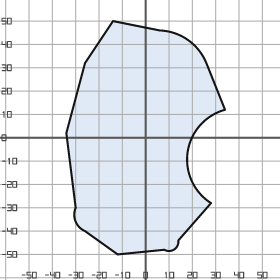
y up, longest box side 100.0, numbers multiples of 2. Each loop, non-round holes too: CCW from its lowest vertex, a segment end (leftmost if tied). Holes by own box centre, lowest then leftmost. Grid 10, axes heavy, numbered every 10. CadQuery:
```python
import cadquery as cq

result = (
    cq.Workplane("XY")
    .moveTo(-12.0, -50.0)
    .lineTo(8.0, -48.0)
    .threePointArc((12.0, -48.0), (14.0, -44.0))
    .lineTo(28.0, -28.0)
    .threePointArc((18.0, -6.0), (34.0, 12.0))
    .lineTo(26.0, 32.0)
    .threePointArc((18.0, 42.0), (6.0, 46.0))
    .lineTo(-14.0, 50.0)
    .lineTo(-26.0, 32.0)
    .lineTo(-34.0, 2.0)
    .lineTo(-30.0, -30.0)
    .threePointArc((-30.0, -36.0), (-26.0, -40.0))
    .close()
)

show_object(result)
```